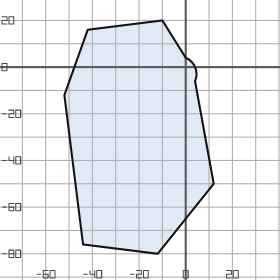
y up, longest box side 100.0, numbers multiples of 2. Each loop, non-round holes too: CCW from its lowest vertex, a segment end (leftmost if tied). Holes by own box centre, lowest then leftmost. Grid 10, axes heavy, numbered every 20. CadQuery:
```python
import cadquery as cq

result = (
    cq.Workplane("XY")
    .moveTo(-12.0, -80.0)
    .lineTo(12.0, -50.0)
    .lineTo(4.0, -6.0)
    .threePointArc((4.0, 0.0), (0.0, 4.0))
    .lineTo(-10.0, 20.0)
    .lineTo(-42.0, 16.0)
    .lineTo(-52.0, -12.0)
    .lineTo(-44.0, -76.0)
    .close()
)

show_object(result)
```